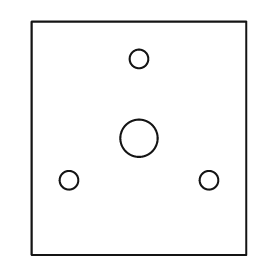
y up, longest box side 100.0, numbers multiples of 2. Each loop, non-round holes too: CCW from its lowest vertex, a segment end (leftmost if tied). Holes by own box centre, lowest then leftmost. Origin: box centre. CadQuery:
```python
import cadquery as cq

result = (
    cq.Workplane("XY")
    .moveTo(-46.0, -50.0)
    .lineTo(46.0, -50.0)
    .lineTo(46.0, 50.0)
    .lineTo(-46.0, 50.0)
    .close()
    .moveTo(-30.0, -18.0)
    .circle(4.0)
    .moveTo(30.0, -18.0)
    .circle(4.0)
    .moveTo(0.0, 0.0)
    .circle(8.0)
    .moveTo(0.0, 34.0)
    .circle(4.0)
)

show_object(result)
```